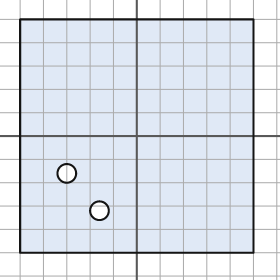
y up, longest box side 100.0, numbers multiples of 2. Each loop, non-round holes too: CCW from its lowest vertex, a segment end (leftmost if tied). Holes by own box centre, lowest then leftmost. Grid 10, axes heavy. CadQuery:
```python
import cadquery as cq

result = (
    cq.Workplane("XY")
    .moveTo(-50.0, -50.0)
    .lineTo(50.0, -50.0)
    .lineTo(50.0, 50.0)
    .lineTo(-50.0, 50.0)
    .close()
    .moveTo(-16.0, -32.0)
    .circle(4.0)
    .moveTo(-30.0, -16.0)
    .circle(4.0)
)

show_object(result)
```